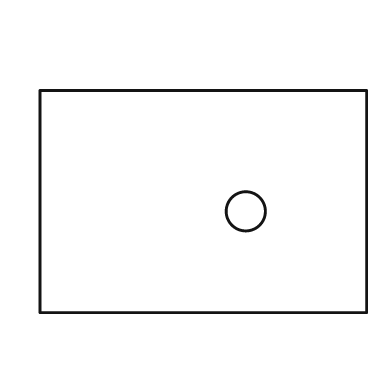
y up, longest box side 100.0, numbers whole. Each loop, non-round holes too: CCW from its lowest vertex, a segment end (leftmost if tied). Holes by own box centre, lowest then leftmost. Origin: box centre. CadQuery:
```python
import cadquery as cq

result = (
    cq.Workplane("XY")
    .moveTo(-50.0, -34.0)
    .lineTo(50.0, -34.0)
    .lineTo(50.0, 34.0)
    .lineTo(-50.0, 34.0)
    .close()
    .moveTo(13.0, -3.0)
    .circle(6.0)
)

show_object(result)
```